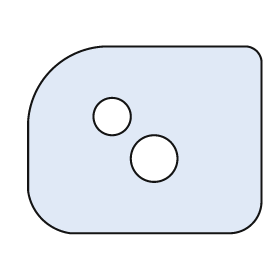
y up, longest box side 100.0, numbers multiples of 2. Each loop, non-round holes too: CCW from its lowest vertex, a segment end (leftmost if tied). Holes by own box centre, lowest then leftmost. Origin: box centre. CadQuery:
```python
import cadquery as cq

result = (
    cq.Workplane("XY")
    .moveTo(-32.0, -40.0)
    .lineTo(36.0, -40.0)
    .threePointArc((46.0, -36.0), (50.0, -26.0))
    .lineTo(50.0, 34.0)
    .threePointArc((48.0, 38.0), (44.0, 40.0))
    .lineTo(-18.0, 40.0)
    .threePointArc((-40.0, 30.0), (-50.0, 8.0))
    .lineTo(-50.0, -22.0)
    .threePointArc((-44.0, -34.0), (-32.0, -40.0))
    .close()
    .moveTo(4.0, -8.0)
    .circle(10.0)
    .moveTo(-14.0, 10.0)
    .circle(8.0)
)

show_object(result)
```